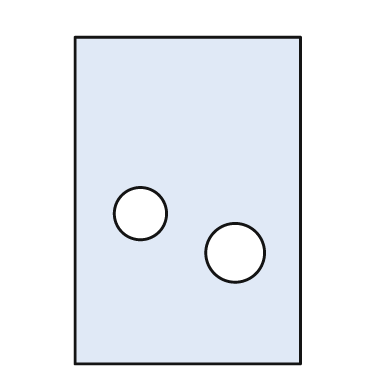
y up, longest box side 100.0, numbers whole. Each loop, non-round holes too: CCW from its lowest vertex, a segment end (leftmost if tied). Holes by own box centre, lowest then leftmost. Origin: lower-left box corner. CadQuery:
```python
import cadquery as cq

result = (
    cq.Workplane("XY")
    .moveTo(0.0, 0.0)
    .lineTo(69.0, 0.0)
    .lineTo(69.0, 100.0)
    .lineTo(0.0, 100.0)
    .close()
    .moveTo(49.0, 34.0)
    .circle(9.0)
    .moveTo(20.0, 46.0)
    .circle(8.0)
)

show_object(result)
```